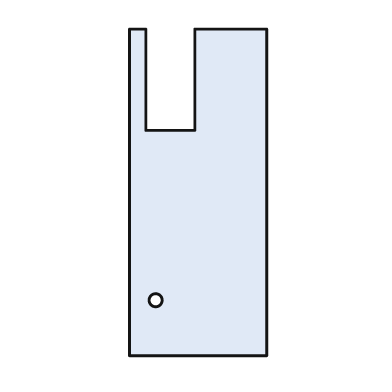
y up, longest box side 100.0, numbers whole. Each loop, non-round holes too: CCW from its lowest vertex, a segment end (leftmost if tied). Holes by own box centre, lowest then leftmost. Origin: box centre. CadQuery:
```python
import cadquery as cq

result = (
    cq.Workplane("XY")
    .moveTo(-21.0, -50.0)
    .lineTo(21.0, -50.0)
    .lineTo(21.0, 50.0)
    .lineTo(-1.0, 50.0)
    .lineTo(-1.0, 19.0)
    .lineTo(-16.0, 19.0)
    .lineTo(-16.0, 50.0)
    .lineTo(-21.0, 50.0)
    .close()
    .moveTo(-13.0, -33.0)
    .circle(2.0)
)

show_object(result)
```